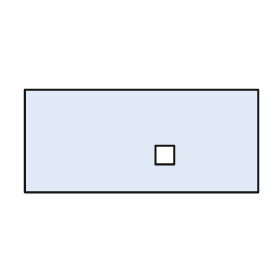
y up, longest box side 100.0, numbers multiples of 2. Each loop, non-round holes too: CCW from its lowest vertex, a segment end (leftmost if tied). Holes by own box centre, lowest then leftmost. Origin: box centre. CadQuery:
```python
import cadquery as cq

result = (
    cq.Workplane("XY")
    .moveTo(-50.0, -22.0)
    .lineTo(50.0, -22.0)
    .lineTo(50.0, 22.0)
    .lineTo(-50.0, 22.0)
    .close()
    .moveTo(6.0, -10.0)
    .lineTo(14.0, -10.0)
    .lineTo(14.0, -2.0)
    .lineTo(6.0, -2.0)
    .close()
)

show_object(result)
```